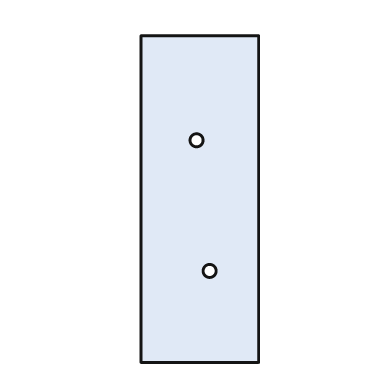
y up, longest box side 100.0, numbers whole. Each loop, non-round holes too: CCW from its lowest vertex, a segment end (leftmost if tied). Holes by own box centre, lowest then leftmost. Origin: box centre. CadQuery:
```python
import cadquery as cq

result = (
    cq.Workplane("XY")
    .moveTo(-18.0, -50.0)
    .lineTo(18.0, -50.0)
    .lineTo(18.0, 50.0)
    .lineTo(-18.0, 50.0)
    .close()
    .moveTo(3.0, -22.0)
    .circle(2.0)
    .moveTo(-1.0, 18.0)
    .circle(2.0)
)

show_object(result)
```